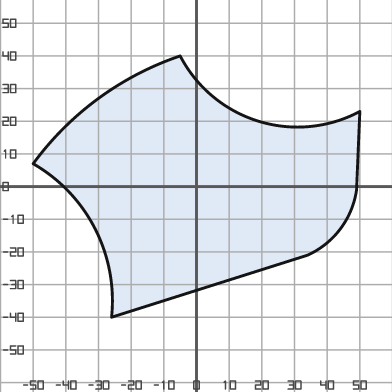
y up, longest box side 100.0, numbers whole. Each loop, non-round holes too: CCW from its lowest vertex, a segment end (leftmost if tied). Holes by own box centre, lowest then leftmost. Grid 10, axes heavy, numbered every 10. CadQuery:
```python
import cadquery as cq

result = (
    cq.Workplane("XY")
    .moveTo(-26.0, -40.0)
    .lineTo(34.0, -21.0)
    .threePointArc((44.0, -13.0), (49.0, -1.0))
    .lineTo(50.0, 23.0)
    .threePointArc((19.0, 20.0), (-5.0, 40.0))
    .threePointArc((-30.0, 27.0), (-50.0, 7.0))
    .threePointArc((-31.0, -13.0), (-26.0, -40.0))
    .close()
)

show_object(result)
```